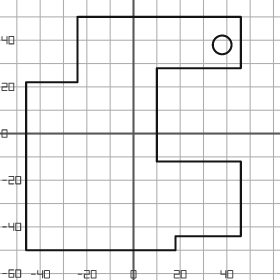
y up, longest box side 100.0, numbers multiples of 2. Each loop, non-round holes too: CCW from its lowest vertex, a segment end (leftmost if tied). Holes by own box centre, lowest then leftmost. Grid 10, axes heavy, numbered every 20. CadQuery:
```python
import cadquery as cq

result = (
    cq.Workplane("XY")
    .moveTo(-46.0, -50.0)
    .lineTo(18.0, -50.0)
    .lineTo(18.0, -44.0)
    .lineTo(46.0, -44.0)
    .lineTo(46.0, -12.0)
    .lineTo(10.0, -12.0)
    .lineTo(10.0, 28.0)
    .lineTo(46.0, 28.0)
    .lineTo(46.0, 50.0)
    .lineTo(-24.0, 50.0)
    .lineTo(-24.0, 22.0)
    .lineTo(-46.0, 22.0)
    .close()
    .moveTo(38.0, 38.0)
    .circle(4.0)
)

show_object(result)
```